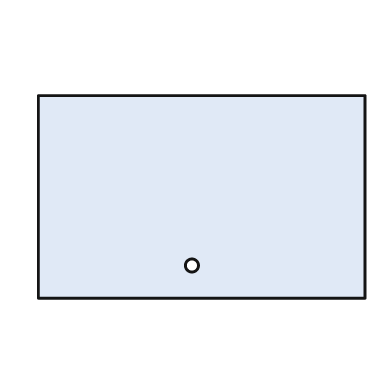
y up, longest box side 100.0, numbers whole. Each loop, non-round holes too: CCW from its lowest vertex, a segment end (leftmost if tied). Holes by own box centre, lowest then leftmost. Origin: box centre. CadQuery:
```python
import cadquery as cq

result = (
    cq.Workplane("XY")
    .moveTo(-50.0, -31.0)
    .lineTo(50.0, -31.0)
    .lineTo(50.0, 31.0)
    .lineTo(-50.0, 31.0)
    .close()
    .moveTo(-3.0, -21.0)
    .circle(2.0)
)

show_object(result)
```